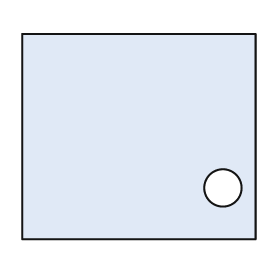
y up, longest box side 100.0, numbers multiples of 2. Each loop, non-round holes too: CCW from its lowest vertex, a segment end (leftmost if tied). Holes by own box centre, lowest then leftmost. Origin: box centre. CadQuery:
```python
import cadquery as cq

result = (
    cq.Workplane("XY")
    .moveTo(-50.0, -44.0)
    .lineTo(50.0, -44.0)
    .lineTo(50.0, 44.0)
    .lineTo(-50.0, 44.0)
    .close()
    .moveTo(36.0, -22.0)
    .circle(8.0)
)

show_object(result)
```